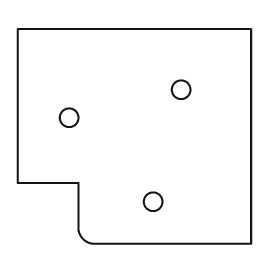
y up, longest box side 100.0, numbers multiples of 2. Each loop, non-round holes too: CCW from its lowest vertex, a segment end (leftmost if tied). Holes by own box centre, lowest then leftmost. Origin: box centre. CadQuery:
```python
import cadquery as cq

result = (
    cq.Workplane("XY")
    .moveTo(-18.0, -46.0)
    .lineTo(50.0, -46.0)
    .lineTo(50.0, 46.0)
    .lineTo(-50.0, 46.0)
    .lineTo(-50.0, -20.0)
    .lineTo(-24.0, -20.0)
    .lineTo(-24.0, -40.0)
    .threePointArc((-22.0, -44.0), (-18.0, -46.0))
    .close()
    .moveTo(8.0, -28.0)
    .circle(4.0)
    .moveTo(-28.0, 8.0)
    .circle(4.0)
    .moveTo(20.0, 20.0)
    .circle(4.0)
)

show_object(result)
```